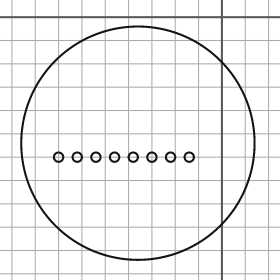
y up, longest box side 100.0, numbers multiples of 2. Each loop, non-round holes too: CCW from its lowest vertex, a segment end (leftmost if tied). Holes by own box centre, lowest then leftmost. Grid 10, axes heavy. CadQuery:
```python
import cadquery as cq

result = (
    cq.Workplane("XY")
    .moveTo(-36.0, -54.0)
    .circle(50.0)
    .moveTo(-70.0, -60.0)
    .circle(2.0)
    .moveTo(-62.0, -60.0)
    .circle(2.0)
    .moveTo(-54.0, -60.0)
    .circle(2.0)
    .moveTo(-46.0, -60.0)
    .circle(2.0)
    .moveTo(-38.0, -60.0)
    .circle(2.0)
    .moveTo(-30.0, -60.0)
    .circle(2.0)
    .moveTo(-22.0, -60.0)
    .circle(2.0)
    .moveTo(-14.0, -60.0)
    .circle(2.0)
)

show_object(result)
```